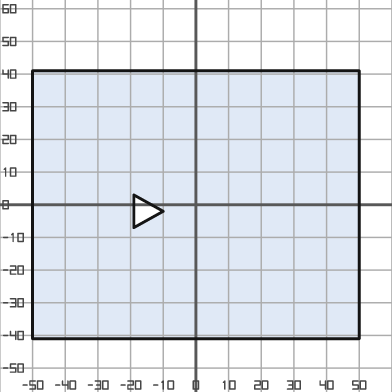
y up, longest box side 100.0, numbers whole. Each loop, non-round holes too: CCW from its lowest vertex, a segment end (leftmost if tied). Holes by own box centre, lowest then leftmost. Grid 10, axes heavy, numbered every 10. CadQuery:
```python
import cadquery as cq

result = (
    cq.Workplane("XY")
    .moveTo(-50.0, -41.0)
    .lineTo(50.0, -41.0)
    .lineTo(50.0, 41.0)
    .lineTo(-50.0, 41.0)
    .close()
    .moveTo(-19.0, -7.0)
    .lineTo(-10.0, -2.0)
    .lineTo(-19.0, 3.0)
    .close()
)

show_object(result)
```